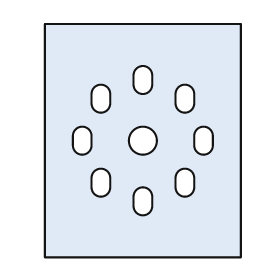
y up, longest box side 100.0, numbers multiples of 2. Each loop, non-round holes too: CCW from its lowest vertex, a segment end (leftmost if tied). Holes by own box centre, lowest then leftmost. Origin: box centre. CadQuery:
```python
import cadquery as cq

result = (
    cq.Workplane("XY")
    .moveTo(-42.0, -50.0)
    .lineTo(42.0, -50.0)
    .lineTo(42.0, 50.0)
    .lineTo(-42.0, 50.0)
    .close()
    .moveTo(-4.0, -28.0)
    .threePointArc((0.0, -32.0), (4.0, -28.0))
    .lineTo(4.0, -24.0)
    .threePointArc((0.0, -20.0), (-4.0, -24.0))
    .close()
    .moveTo(-22.0, -20.0)
    .threePointArc((-18.0, -24.0), (-14.0, -20.0))
    .lineTo(-14.0, -16.0)
    .threePointArc((-18.0, -12.0), (-22.0, -16.0))
    .close()
    .moveTo(14.0, -20.0)
    .threePointArc((18.0, -24.0), (22.0, -20.0))
    .lineTo(22.0, -16.0)
    .threePointArc((18.0, -12.0), (14.0, -16.0))
    .close()
    .moveTo(-30.0, -2.0)
    .threePointArc((-26.0, -6.0), (-22.0, -2.0))
    .lineTo(-22.0, 2.0)
    .threePointArc((-26.0, 6.0), (-30.0, 2.0))
    .close()
    .moveTo(0.0, 0.0)
    .circle(6.0)
    .moveTo(22.0, -2.0)
    .threePointArc((26.0, -6.0), (30.0, -2.0))
    .lineTo(30.0, 2.0)
    .threePointArc((26.0, 6.0), (22.0, 2.0))
    .close()
    .moveTo(-22.0, 16.0)
    .threePointArc((-18.0, 12.0), (-14.0, 16.0))
    .lineTo(-14.0, 20.0)
    .threePointArc((-18.0, 24.0), (-22.0, 20.0))
    .close()
    .moveTo(14.0, 16.0)
    .threePointArc((18.0, 12.0), (22.0, 16.0))
    .lineTo(22.0, 20.0)
    .threePointArc((18.0, 24.0), (14.0, 20.0))
    .close()
    .moveTo(-4.0, 24.0)
    .threePointArc((0.0, 20.0), (4.0, 24.0))
    .lineTo(4.0, 28.0)
    .threePointArc((0.0, 32.0), (-4.0, 28.0))
    .close()
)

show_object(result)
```